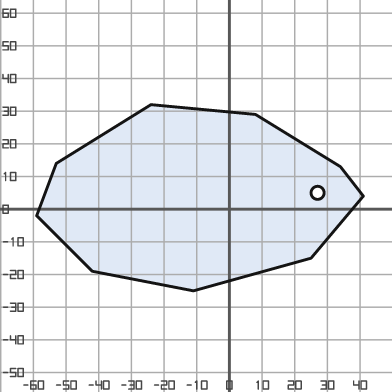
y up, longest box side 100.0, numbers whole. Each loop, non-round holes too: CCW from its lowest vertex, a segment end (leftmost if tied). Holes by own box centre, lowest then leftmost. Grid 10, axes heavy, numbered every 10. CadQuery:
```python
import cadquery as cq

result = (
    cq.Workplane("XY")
    .moveTo(-11.0, -25.0)
    .lineTo(25.0, -15.0)
    .lineTo(41.0, 4.0)
    .lineTo(34.0, 13.0)
    .lineTo(8.0, 29.0)
    .lineTo(-24.0, 32.0)
    .lineTo(-53.0, 14.0)
    .lineTo(-59.0, -2.0)
    .lineTo(-42.0, -19.0)
    .close()
    .moveTo(27.0, 5.0)
    .circle(2.0)
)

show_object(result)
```